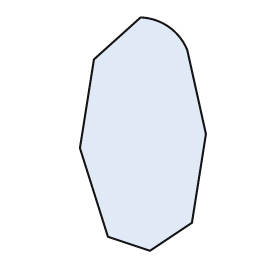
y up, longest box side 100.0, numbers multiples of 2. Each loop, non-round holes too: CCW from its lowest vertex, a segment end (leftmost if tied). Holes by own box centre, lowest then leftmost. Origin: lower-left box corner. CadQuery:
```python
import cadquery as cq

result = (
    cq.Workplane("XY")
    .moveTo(30.0, 0.0)
    .lineTo(48.0, 12.0)
    .lineTo(54.0, 50.0)
    .lineTo(46.0, 86.0)
    .threePointArc((38.0, 96.0), (26.0, 100.0))
    .lineTo(6.0, 82.0)
    .lineTo(0.0, 44.0)
    .lineTo(12.0, 6.0)
    .close()
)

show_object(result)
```